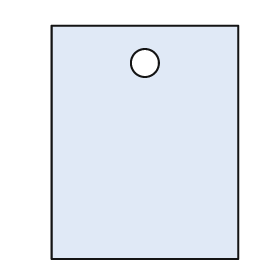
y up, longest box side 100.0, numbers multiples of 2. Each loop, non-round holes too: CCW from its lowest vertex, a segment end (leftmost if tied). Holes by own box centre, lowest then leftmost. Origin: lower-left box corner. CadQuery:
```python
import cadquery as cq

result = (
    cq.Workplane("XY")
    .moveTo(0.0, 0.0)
    .lineTo(80.0, 0.0)
    .lineTo(80.0, 100.0)
    .lineTo(0.0, 100.0)
    .close()
    .moveTo(40.0, 84.0)
    .circle(6.0)
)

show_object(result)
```